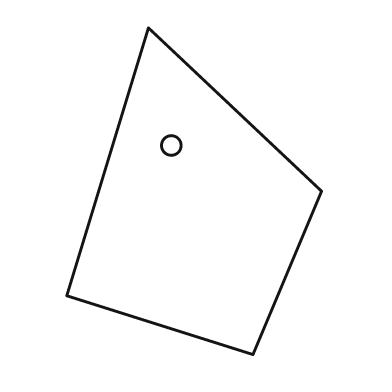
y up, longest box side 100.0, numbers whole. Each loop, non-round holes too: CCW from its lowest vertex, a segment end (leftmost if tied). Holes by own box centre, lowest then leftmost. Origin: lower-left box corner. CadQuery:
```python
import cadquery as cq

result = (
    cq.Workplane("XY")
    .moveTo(57.0, 0.0)
    .lineTo(78.0, 50.0)
    .lineTo(25.0, 100.0)
    .lineTo(0.0, 18.0)
    .close()
    .moveTo(32.0, 64.0)
    .circle(3.0)
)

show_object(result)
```